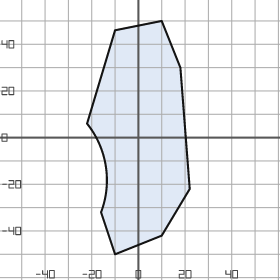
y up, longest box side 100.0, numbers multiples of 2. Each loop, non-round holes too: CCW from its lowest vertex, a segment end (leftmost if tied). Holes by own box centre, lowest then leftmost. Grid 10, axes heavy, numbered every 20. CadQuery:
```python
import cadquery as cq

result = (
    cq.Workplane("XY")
    .moveTo(-10.0, -50.0)
    .lineTo(10.0, -42.0)
    .lineTo(22.0, -22.0)
    .lineTo(18.0, 30.0)
    .lineTo(10.0, 50.0)
    .lineTo(-10.0, 46.0)
    .lineTo(-22.0, 6.0)
    .threePointArc((-14.0, -12.0), (-16.0, -32.0))
    .close()
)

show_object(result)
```